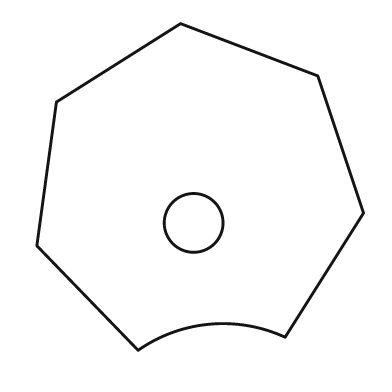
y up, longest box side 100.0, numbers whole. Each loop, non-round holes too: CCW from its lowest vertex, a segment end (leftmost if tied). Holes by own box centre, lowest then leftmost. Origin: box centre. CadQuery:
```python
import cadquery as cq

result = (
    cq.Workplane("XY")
    .moveTo(-19.0, -50.0)
    .threePointArc((3.0, -42.0), (26.0, -46.0))
    .lineTo(50.0, -8.0)
    .lineTo(36.0, 34.0)
    .lineTo(-6.0, 50.0)
    .lineTo(-44.0, 26.0)
    .lineTo(-50.0, -18.0)
    .close()
    .moveTo(-2.0, -11.0)
    .circle(9.0)
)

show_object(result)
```